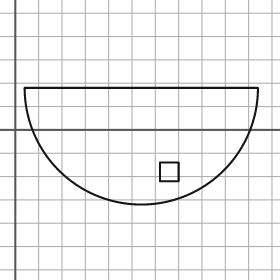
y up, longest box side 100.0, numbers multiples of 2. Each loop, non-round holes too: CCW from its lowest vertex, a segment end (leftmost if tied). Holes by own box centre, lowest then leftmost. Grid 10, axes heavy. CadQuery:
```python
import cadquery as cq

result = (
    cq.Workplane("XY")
    .moveTo(4.0, 18.0)
    .threePointArc((54.0, -32.0), (104.0, 18.0))
    .close()
    .moveTo(62.0, -22.0)
    .lineTo(70.0, -22.0)
    .lineTo(70.0, -14.0)
    .lineTo(62.0, -14.0)
    .close()
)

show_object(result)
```